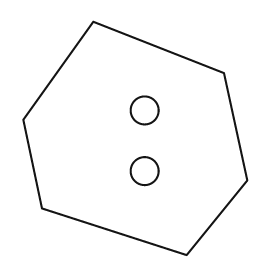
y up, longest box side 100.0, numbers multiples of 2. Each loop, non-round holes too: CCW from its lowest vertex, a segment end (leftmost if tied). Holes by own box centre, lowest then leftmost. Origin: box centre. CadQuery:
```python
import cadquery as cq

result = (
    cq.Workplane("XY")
    .moveTo(22.0, -50.0)
    .lineTo(48.0, -18.0)
    .lineTo(38.0, 28.0)
    .lineTo(-18.0, 50.0)
    .lineTo(-48.0, 8.0)
    .lineTo(-40.0, -30.0)
    .close()
    .moveTo(4.0, -14.0)
    .circle(6.0)
    .moveTo(4.0, 12.0)
    .circle(6.0)
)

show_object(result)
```